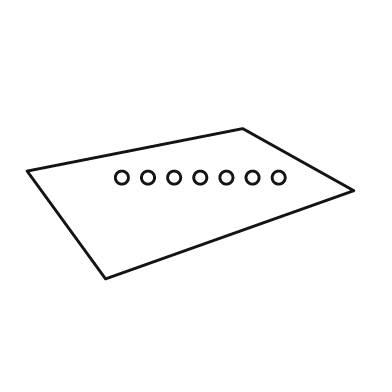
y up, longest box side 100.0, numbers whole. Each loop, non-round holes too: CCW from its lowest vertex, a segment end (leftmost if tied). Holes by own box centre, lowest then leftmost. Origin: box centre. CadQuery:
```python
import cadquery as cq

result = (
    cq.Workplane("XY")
    .moveTo(-26.0, -23.0)
    .lineTo(50.0, 4.0)
    .lineTo(16.0, 23.0)
    .lineTo(-50.0, 10.0)
    .close()
    .moveTo(-21.0, 8.0)
    .circle(2.0)
    .moveTo(-13.0, 8.0)
    .circle(2.0)
    .moveTo(-5.0, 8.0)
    .circle(2.0)
    .moveTo(3.0, 8.0)
    .circle(2.0)
    .moveTo(11.0, 8.0)
    .circle(2.0)
    .moveTo(19.0, 8.0)
    .circle(2.0)
    .moveTo(27.0, 8.0)
    .circle(2.0)
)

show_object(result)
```